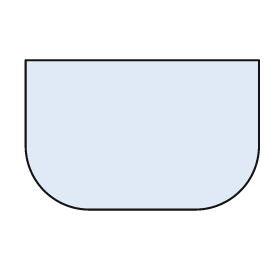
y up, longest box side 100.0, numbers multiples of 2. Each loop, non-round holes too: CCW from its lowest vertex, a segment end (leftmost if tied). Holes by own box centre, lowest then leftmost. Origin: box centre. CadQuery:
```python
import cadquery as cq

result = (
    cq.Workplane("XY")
    .moveTo(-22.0, -32.0)
    .lineTo(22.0, -32.0)
    .threePointArc((42.0, -24.0), (50.0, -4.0))
    .lineTo(50.0, 32.0)
    .lineTo(-50.0, 32.0)
    .lineTo(-50.0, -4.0)
    .threePointArc((-42.0, -24.0), (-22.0, -32.0))
    .close()
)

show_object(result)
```